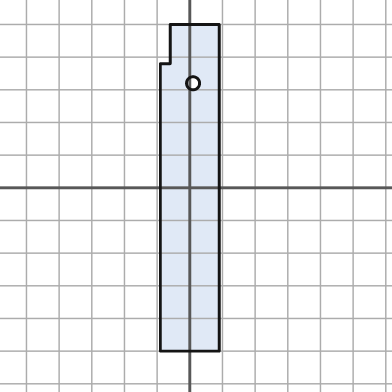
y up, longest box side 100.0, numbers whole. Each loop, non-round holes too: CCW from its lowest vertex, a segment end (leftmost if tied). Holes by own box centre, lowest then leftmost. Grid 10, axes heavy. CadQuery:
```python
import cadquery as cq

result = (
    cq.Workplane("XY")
    .moveTo(-9.0, -50.0)
    .lineTo(9.0, -50.0)
    .lineTo(9.0, 50.0)
    .lineTo(-6.0, 50.0)
    .lineTo(-6.0, 38.0)
    .lineTo(-9.0, 38.0)
    .close()
    .moveTo(1.0, 32.0)
    .circle(2.0)
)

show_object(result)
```